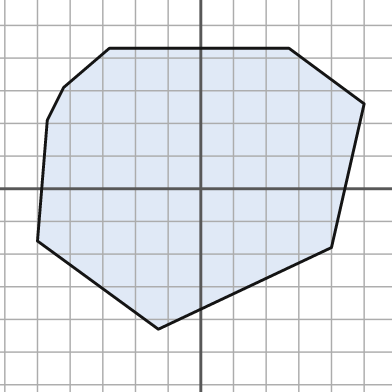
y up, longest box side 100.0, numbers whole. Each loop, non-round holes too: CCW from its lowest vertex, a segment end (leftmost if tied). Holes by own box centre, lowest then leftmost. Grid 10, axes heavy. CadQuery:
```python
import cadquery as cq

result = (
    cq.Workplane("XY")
    .moveTo(-13.0, -43.0)
    .lineTo(40.0, -18.0)
    .lineTo(50.0, 26.0)
    .lineTo(27.0, 43.0)
    .lineTo(-28.0, 43.0)
    .lineTo(-42.0, 31.0)
    .lineTo(-47.0, 21.0)
    .lineTo(-50.0, -16.0)
    .close()
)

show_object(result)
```